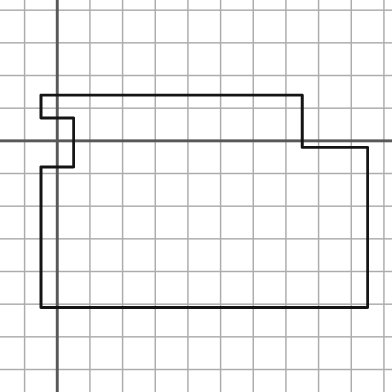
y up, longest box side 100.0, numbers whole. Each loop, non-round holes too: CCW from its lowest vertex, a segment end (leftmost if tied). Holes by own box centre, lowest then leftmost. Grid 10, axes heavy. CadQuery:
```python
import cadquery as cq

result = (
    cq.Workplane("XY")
    .moveTo(-5.0, -51.0)
    .lineTo(95.0, -51.0)
    .lineTo(95.0, -2.0)
    .lineTo(75.0, -2.0)
    .lineTo(75.0, 14.0)
    .lineTo(-5.0, 14.0)
    .lineTo(-5.0, 7.0)
    .lineTo(5.0, 7.0)
    .lineTo(5.0, -8.0)
    .lineTo(-5.0, -8.0)
    .close()
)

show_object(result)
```